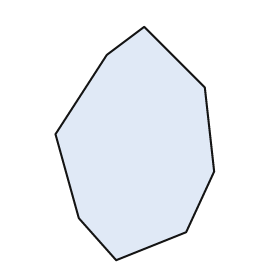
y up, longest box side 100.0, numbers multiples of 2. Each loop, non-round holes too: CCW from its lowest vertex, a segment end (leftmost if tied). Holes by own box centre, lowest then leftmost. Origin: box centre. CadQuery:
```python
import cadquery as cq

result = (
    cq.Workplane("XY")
    .moveTo(-8.0, -50.0)
    .lineTo(22.0, -38.0)
    .lineTo(34.0, -12.0)
    .lineTo(30.0, 24.0)
    .lineTo(4.0, 50.0)
    .lineTo(-12.0, 38.0)
    .lineTo(-34.0, 4.0)
    .lineTo(-24.0, -32.0)
    .close()
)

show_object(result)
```